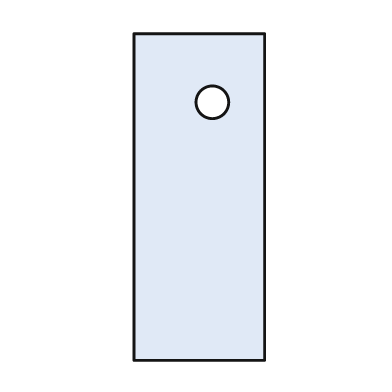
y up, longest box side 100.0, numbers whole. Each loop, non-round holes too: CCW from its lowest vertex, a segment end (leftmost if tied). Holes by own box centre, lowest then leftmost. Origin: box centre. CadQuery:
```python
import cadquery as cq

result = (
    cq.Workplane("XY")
    .moveTo(-20.0, -50.0)
    .lineTo(20.0, -50.0)
    .lineTo(20.0, 50.0)
    .lineTo(-20.0, 50.0)
    .close()
    .moveTo(4.0, 29.0)
    .circle(5.0)
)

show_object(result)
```